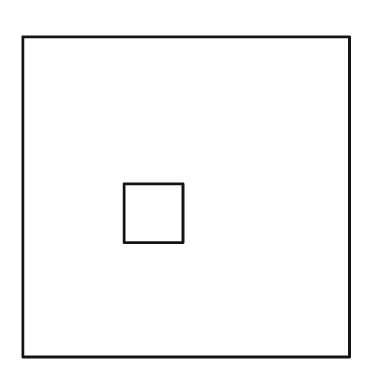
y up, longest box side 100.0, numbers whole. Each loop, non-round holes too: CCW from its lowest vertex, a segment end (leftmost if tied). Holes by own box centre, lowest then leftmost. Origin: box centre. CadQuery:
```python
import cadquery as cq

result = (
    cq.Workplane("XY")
    .moveTo(-50.0, -49.0)
    .lineTo(50.0, -49.0)
    .lineTo(50.0, 49.0)
    .lineTo(-50.0, 49.0)
    .close()
    .moveTo(-19.0, -14.0)
    .lineTo(-1.0, -14.0)
    .lineTo(-1.0, 4.0)
    .lineTo(-19.0, 4.0)
    .close()
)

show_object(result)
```